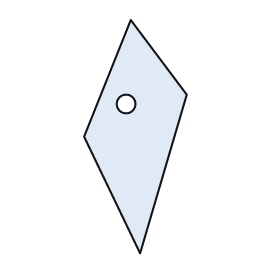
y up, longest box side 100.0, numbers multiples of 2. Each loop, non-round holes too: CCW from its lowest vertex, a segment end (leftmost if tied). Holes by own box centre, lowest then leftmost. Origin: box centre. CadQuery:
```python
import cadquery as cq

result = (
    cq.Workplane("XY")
    .moveTo(2.0, -50.0)
    .lineTo(22.0, 18.0)
    .lineTo(-2.0, 50.0)
    .lineTo(-22.0, 0.0)
    .close()
    .moveTo(-4.0, 14.0)
    .circle(4.0)
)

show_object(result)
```